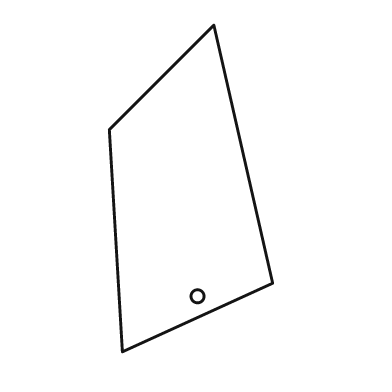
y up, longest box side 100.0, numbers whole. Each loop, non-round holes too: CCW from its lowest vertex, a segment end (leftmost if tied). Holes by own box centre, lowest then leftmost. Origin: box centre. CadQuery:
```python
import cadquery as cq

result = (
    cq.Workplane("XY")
    .moveTo(-21.0, -50.0)
    .lineTo(25.0, -29.0)
    .lineTo(7.0, 50.0)
    .lineTo(-25.0, 18.0)
    .close()
    .moveTo(2.0, -33.0)
    .circle(2.0)
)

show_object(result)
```